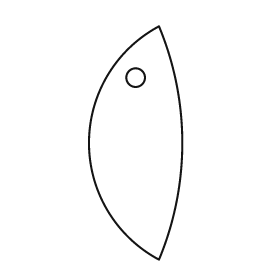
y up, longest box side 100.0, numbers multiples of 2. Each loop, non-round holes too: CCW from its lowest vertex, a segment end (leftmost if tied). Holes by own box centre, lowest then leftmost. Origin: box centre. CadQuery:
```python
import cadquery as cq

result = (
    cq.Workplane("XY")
    .moveTo(10.0, -50.0)
    .threePointArc((20.0, 0.0), (10.0, 50.0))
    .threePointArc((-20.0, 0.0), (10.0, -50.0))
    .close()
    .moveTo(0.0, 28.0)
    .circle(4.0)
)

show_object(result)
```